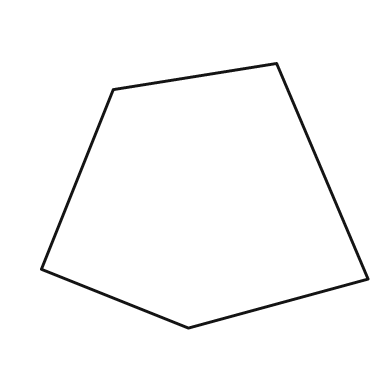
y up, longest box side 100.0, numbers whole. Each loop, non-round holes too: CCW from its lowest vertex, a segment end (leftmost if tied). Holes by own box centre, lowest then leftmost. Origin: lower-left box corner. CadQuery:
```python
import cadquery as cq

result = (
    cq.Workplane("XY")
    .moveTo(45.0, 0.0)
    .lineTo(100.0, 15.0)
    .lineTo(72.0, 81.0)
    .lineTo(22.0, 73.0)
    .lineTo(0.0, 18.0)
    .close()
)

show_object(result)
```